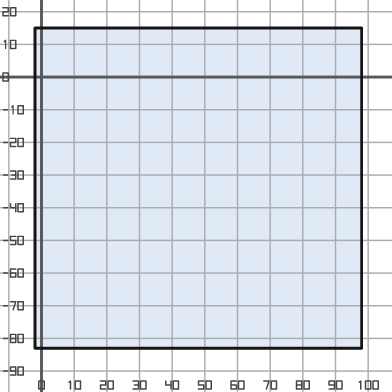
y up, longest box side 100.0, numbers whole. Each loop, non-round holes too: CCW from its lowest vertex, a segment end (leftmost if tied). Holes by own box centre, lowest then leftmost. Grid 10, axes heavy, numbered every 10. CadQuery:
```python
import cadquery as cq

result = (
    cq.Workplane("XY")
    .moveTo(-2.0, -83.0)
    .lineTo(98.0, -83.0)
    .lineTo(98.0, 15.0)
    .lineTo(-2.0, 15.0)
    .close()
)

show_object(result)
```